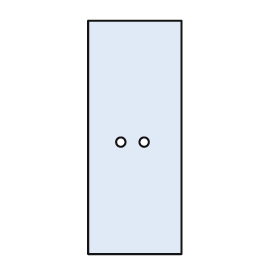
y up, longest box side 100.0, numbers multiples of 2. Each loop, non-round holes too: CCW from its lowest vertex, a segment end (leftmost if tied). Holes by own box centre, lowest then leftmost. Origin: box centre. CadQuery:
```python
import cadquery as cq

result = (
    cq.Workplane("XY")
    .moveTo(-20.0, -50.0)
    .lineTo(20.0, -50.0)
    .lineTo(20.0, 50.0)
    .lineTo(-20.0, 50.0)
    .close()
    .moveTo(-6.0, -2.0)
    .circle(2.0)
    .moveTo(4.0, -2.0)
    .circle(2.0)
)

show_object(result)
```